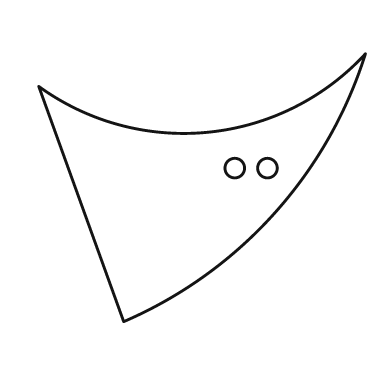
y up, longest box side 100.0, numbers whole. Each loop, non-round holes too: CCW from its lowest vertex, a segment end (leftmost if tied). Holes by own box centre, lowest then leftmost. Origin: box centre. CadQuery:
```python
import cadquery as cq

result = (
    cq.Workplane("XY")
    .moveTo(-24.0, -41.0)
    .threePointArc((22.0, -8.0), (50.0, 41.0))
    .threePointArc((2.0, 17.0), (-50.0, 31.0))
    .close()
    .moveTo(10.0, 6.0)
    .circle(3.0)
    .moveTo(20.0, 6.0)
    .circle(3.0)
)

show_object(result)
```